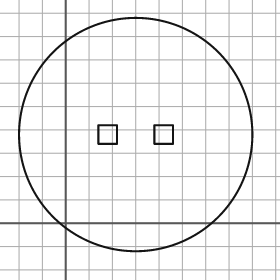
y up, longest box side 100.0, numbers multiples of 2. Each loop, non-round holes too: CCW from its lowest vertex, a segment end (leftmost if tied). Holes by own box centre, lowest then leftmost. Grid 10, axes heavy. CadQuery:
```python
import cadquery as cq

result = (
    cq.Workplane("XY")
    .moveTo(30.0, 38.0)
    .circle(50.0)
    .moveTo(14.0, 34.0)
    .lineTo(22.0, 34.0)
    .lineTo(22.0, 42.0)
    .lineTo(14.0, 42.0)
    .close()
    .moveTo(38.0, 34.0)
    .lineTo(46.0, 34.0)
    .lineTo(46.0, 42.0)
    .lineTo(38.0, 42.0)
    .close()
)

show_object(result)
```